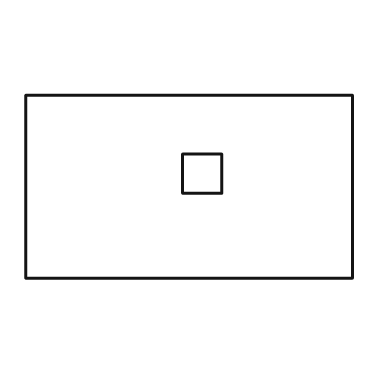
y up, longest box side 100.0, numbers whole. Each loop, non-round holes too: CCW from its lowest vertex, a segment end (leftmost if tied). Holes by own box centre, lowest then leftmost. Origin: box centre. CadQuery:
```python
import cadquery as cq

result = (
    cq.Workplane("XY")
    .moveTo(-50.0, -28.0)
    .lineTo(50.0, -28.0)
    .lineTo(50.0, 28.0)
    .lineTo(-50.0, 28.0)
    .close()
    .moveTo(-2.0, -2.0)
    .lineTo(10.0, -2.0)
    .lineTo(10.0, 10.0)
    .lineTo(-2.0, 10.0)
    .close()
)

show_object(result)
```